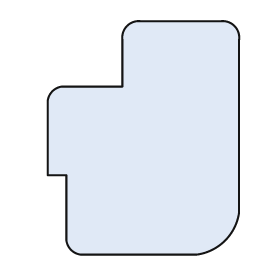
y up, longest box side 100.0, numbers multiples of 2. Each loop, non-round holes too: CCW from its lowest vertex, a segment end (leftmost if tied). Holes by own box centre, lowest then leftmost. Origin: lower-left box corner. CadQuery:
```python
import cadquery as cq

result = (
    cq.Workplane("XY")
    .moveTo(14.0, 0.0)
    .lineTo(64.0, 0.0)
    .threePointArc((76.0, 6.0), (82.0, 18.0))
    .lineTo(82.0, 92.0)
    .threePointArc((80.0, 98.0), (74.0, 100.0))
    .lineTo(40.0, 100.0)
    .threePointArc((34.0, 98.0), (32.0, 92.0))
    .lineTo(32.0, 72.0)
    .lineTo(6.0, 72.0)
    .threePointArc((2.0, 70.0), (0.0, 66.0))
    .lineTo(0.0, 34.0)
    .lineTo(8.0, 34.0)
    .lineTo(8.0, 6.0)
    .threePointArc((10.0, 2.0), (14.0, 0.0))
    .close()
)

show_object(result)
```